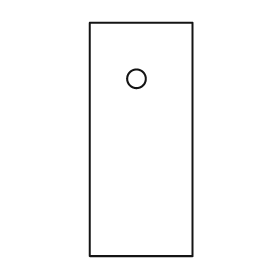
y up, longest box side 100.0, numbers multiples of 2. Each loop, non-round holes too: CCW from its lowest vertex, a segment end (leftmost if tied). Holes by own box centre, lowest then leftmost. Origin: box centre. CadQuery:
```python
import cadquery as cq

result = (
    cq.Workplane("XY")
    .moveTo(-22.0, -50.0)
    .lineTo(22.0, -50.0)
    .lineTo(22.0, 50.0)
    .lineTo(-22.0, 50.0)
    .close()
    .moveTo(-2.0, 26.0)
    .circle(4.0)
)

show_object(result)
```